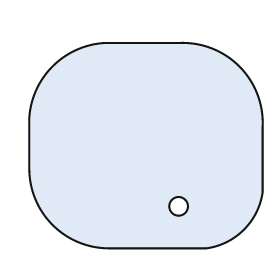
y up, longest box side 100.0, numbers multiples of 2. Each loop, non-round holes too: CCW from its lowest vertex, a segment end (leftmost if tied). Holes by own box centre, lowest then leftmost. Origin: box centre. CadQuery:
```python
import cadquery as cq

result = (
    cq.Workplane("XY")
    .moveTo(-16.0, -44.0)
    .lineTo(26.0, -44.0)
    .threePointArc((42.0, -36.0), (50.0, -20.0))
    .lineTo(50.0, 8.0)
    .threePointArc((40.0, 34.0), (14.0, 44.0))
    .lineTo(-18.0, 44.0)
    .threePointArc((-40.0, 34.0), (-50.0, 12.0))
    .lineTo(-50.0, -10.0)
    .threePointArc((-40.0, -34.0), (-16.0, -44.0))
    .close()
    .moveTo(14.0, -26.0)
    .circle(4.0)
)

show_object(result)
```